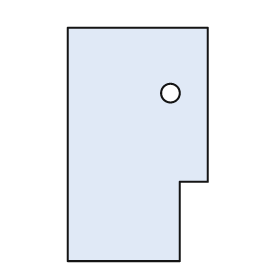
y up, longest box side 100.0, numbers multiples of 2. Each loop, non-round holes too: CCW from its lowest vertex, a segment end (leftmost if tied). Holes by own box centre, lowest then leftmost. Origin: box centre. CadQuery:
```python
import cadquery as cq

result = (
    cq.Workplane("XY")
    .moveTo(-30.0, -50.0)
    .lineTo(18.0, -50.0)
    .lineTo(18.0, -16.0)
    .lineTo(30.0, -16.0)
    .lineTo(30.0, 50.0)
    .lineTo(-30.0, 50.0)
    .close()
    .moveTo(14.0, 22.0)
    .circle(4.0)
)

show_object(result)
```